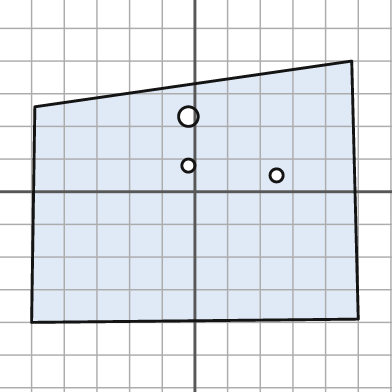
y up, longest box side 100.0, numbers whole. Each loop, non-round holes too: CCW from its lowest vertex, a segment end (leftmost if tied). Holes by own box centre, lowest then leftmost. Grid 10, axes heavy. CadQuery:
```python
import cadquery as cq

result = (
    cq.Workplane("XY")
    .moveTo(-50.0, -40.0)
    .lineTo(50.0, -39.0)
    .lineTo(48.0, 40.0)
    .lineTo(-49.0, 26.0)
    .close()
    .moveTo(25.0, 5.0)
    .circle(2.0)
    .moveTo(-2.0, 8.0)
    .circle(2.0)
    .moveTo(-2.0, 23.0)
    .circle(3.0)
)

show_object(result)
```